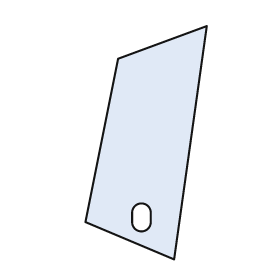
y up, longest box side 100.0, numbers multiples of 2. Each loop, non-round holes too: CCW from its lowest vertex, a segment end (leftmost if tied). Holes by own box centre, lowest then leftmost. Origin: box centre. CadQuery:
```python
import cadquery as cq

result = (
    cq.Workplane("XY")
    .moveTo(12.0, -50.0)
    .lineTo(26.0, 50.0)
    .lineTo(-12.0, 36.0)
    .lineTo(-26.0, -34.0)
    .close()
    .moveTo(-6.0, -34.0)
    .threePointArc((-2.0, -38.0), (2.0, -34.0))
    .lineTo(2.0, -30.0)
    .threePointArc((-2.0, -26.0), (-6.0, -30.0))
    .close()
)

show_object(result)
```